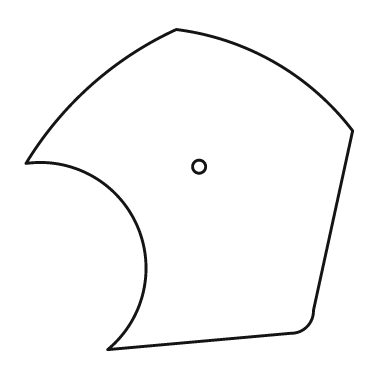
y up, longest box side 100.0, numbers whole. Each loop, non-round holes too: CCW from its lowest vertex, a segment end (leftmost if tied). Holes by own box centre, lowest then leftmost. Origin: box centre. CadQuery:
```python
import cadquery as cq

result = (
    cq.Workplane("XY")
    .moveTo(-25.0, -49.0)
    .lineTo(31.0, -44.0)
    .threePointArc((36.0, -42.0), (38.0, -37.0))
    .lineTo(50.0, 18.0)
    .threePointArc((26.0, 39.0), (-4.0, 49.0))
    .threePointArc((-30.0, 32.0), (-50.0, 8.0))
    .threePointArc((-16.0, -11.0), (-25.0, -49.0))
    .close()
    .moveTo(3.0, 7.0)
    .circle(2.0)
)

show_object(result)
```